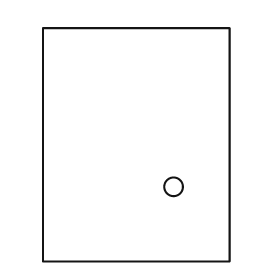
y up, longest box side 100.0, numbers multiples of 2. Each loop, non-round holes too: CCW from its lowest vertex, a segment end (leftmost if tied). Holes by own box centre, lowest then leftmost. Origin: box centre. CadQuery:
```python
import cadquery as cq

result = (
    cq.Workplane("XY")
    .moveTo(-40.0, -50.0)
    .lineTo(40.0, -50.0)
    .lineTo(40.0, 50.0)
    .lineTo(-40.0, 50.0)
    .close()
    .moveTo(16.0, -18.0)
    .circle(4.0)
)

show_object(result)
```